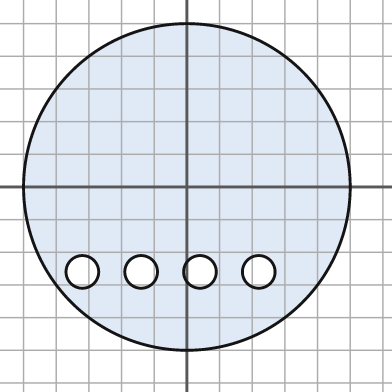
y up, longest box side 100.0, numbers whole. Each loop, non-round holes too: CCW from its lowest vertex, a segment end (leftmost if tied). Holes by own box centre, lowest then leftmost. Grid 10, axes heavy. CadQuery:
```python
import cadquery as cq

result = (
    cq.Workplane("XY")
    .moveTo(0.0, 0.0)
    .circle(50.0)
    .moveTo(-32.0, -26.0)
    .circle(5.0)
    .moveTo(-14.0, -26.0)
    .circle(5.0)
    .moveTo(4.0, -26.0)
    .circle(5.0)
    .moveTo(22.0, -26.0)
    .circle(5.0)
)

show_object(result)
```